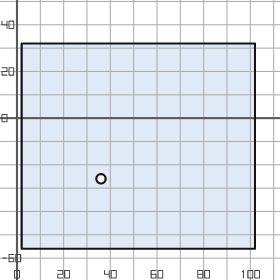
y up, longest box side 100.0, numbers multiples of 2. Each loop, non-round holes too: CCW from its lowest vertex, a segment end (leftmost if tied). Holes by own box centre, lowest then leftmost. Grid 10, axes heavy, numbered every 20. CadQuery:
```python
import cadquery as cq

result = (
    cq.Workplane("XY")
    .moveTo(2.0, -56.0)
    .lineTo(102.0, -56.0)
    .lineTo(102.0, 32.0)
    .lineTo(2.0, 32.0)
    .close()
    .moveTo(36.0, -26.0)
    .circle(2.0)
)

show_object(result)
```